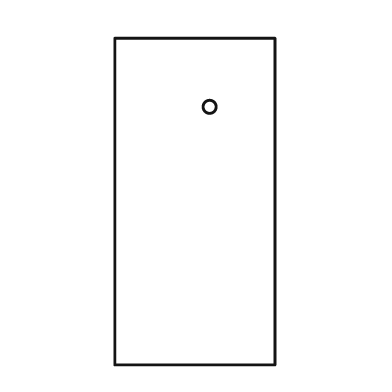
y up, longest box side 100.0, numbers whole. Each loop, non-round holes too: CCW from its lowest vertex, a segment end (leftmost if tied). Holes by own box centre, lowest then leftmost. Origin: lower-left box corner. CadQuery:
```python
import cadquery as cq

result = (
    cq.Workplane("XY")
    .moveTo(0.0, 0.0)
    .lineTo(49.0, 0.0)
    .lineTo(49.0, 100.0)
    .lineTo(0.0, 100.0)
    .close()
    .moveTo(29.0, 79.0)
    .circle(2.0)
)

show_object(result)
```